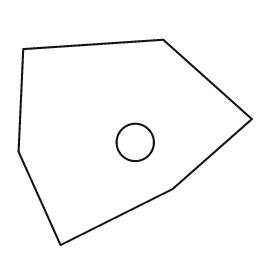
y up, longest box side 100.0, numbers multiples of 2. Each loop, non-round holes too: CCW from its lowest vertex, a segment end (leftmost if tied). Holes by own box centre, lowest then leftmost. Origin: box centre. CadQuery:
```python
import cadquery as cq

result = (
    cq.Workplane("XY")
    .moveTo(-32.0, -44.0)
    .lineTo(16.0, -20.0)
    .lineTo(50.0, 10.0)
    .lineTo(12.0, 44.0)
    .lineTo(-48.0, 40.0)
    .lineTo(-50.0, -4.0)
    .close()
    .moveTo(0.0, 0.0)
    .circle(8.0)
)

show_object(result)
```